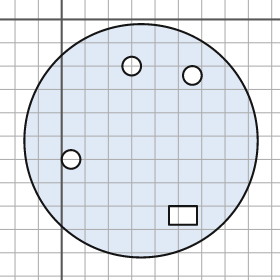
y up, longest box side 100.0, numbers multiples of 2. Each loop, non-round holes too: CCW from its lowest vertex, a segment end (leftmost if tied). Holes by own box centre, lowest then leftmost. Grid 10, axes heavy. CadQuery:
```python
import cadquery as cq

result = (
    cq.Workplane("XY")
    .moveTo(34.0, -52.0)
    .circle(50.0)
    .moveTo(46.0, -88.0)
    .lineTo(58.0, -88.0)
    .lineTo(58.0, -80.0)
    .lineTo(46.0, -80.0)
    .close()
    .moveTo(4.0, -60.0)
    .circle(4.0)
    .moveTo(56.0, -24.0)
    .circle(4.0)
    .moveTo(30.0, -20.0)
    .circle(4.0)
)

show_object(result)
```